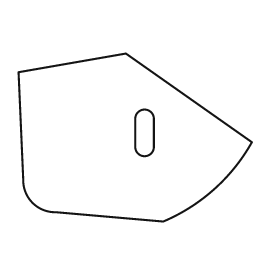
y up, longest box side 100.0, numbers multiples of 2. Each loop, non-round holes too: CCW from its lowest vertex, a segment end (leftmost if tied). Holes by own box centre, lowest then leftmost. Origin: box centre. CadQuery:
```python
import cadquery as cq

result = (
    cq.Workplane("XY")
    .moveTo(12.0, -36.0)
    .threePointArc((34.0, -22.0), (50.0, -2.0))
    .lineTo(-4.0, 36.0)
    .lineTo(-50.0, 28.0)
    .lineTo(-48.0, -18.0)
    .threePointArc((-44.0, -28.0), (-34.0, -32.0))
    .close()
    .moveTo(0.0, -4.0)
    .threePointArc((4.0, -8.0), (8.0, -4.0))
    .lineTo(8.0, 8.0)
    .threePointArc((4.0, 12.0), (0.0, 8.0))
    .close()
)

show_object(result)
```